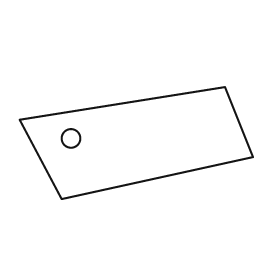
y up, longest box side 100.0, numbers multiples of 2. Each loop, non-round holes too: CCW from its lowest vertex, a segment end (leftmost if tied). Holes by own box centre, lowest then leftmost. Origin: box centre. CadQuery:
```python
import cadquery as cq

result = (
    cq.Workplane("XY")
    .moveTo(-32.0, -24.0)
    .lineTo(50.0, -6.0)
    .lineTo(38.0, 24.0)
    .lineTo(-50.0, 10.0)
    .close()
    .moveTo(-28.0, 2.0)
    .circle(4.0)
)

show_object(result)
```